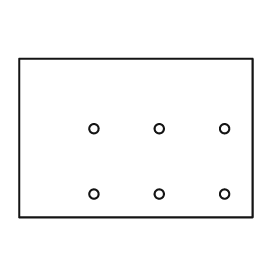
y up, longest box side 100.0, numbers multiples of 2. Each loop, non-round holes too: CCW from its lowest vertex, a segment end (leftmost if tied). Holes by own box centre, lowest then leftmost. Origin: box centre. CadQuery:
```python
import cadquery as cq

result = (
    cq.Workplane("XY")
    .moveTo(-50.0, -34.0)
    .lineTo(50.0, -34.0)
    .lineTo(50.0, 34.0)
    .lineTo(-50.0, 34.0)
    .close()
    .moveTo(-18.0, -24.0)
    .circle(2.0)
    .moveTo(10.0, -24.0)
    .circle(2.0)
    .moveTo(38.0, -24.0)
    .circle(2.0)
    .moveTo(-18.0, 4.0)
    .circle(2.0)
    .moveTo(10.0, 4.0)
    .circle(2.0)
    .moveTo(38.0, 4.0)
    .circle(2.0)
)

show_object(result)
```